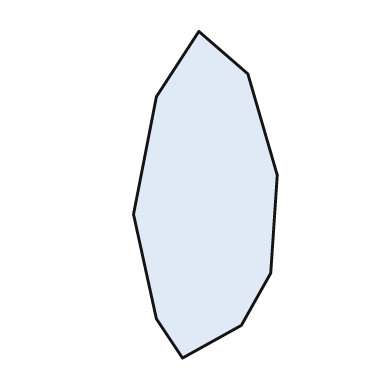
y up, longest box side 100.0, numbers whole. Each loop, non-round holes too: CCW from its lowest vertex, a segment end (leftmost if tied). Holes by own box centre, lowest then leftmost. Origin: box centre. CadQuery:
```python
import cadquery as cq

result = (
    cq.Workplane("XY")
    .moveTo(-7.0, -50.0)
    .lineTo(11.0, -40.0)
    .lineTo(20.0, -24.0)
    .lineTo(22.0, 6.0)
    .lineTo(13.0, 37.0)
    .lineTo(-2.0, 50.0)
    .lineTo(-15.0, 30.0)
    .lineTo(-22.0, -6.0)
    .lineTo(-15.0, -38.0)
    .close()
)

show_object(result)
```